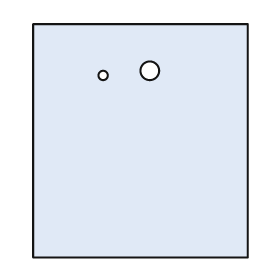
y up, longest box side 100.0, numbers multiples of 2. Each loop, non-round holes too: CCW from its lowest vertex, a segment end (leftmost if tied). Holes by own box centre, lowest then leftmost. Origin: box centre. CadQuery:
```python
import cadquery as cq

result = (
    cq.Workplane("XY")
    .moveTo(-46.0, -50.0)
    .lineTo(46.0, -50.0)
    .lineTo(46.0, 50.0)
    .lineTo(-46.0, 50.0)
    .close()
    .moveTo(-16.0, 28.0)
    .circle(2.0)
    .moveTo(4.0, 30.0)
    .circle(4.0)
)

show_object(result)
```